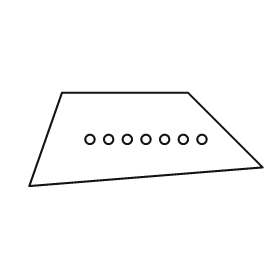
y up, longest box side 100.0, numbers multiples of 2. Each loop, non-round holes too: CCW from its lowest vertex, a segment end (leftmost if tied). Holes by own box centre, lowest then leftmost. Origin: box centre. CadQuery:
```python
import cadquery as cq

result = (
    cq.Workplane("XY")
    .moveTo(-50.0, -20.0)
    .lineTo(50.0, -12.0)
    .lineTo(18.0, 20.0)
    .lineTo(-36.0, 20.0)
    .close()
    .moveTo(-24.0, 0.0)
    .circle(2.0)
    .moveTo(-16.0, 0.0)
    .circle(2.0)
    .moveTo(-8.0, 0.0)
    .circle(2.0)
    .moveTo(0.0, 0.0)
    .circle(2.0)
    .moveTo(8.0, 0.0)
    .circle(2.0)
    .moveTo(16.0, 0.0)
    .circle(2.0)
    .moveTo(24.0, 0.0)
    .circle(2.0)
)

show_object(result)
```